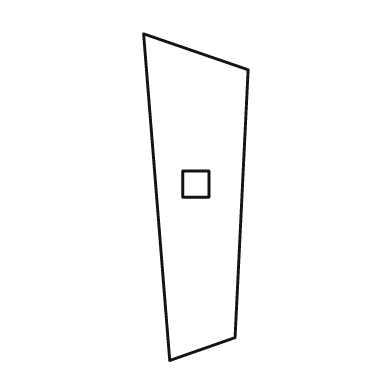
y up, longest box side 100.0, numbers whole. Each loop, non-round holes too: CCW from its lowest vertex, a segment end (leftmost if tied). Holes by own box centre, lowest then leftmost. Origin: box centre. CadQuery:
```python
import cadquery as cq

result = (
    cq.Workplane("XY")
    .moveTo(-8.0, -50.0)
    .lineTo(12.0, -43.0)
    .lineTo(16.0, 39.0)
    .lineTo(-16.0, 50.0)
    .close()
    .moveTo(-4.0, 0.0)
    .lineTo(4.0, 0.0)
    .lineTo(4.0, 8.0)
    .lineTo(-4.0, 8.0)
    .close()
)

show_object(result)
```